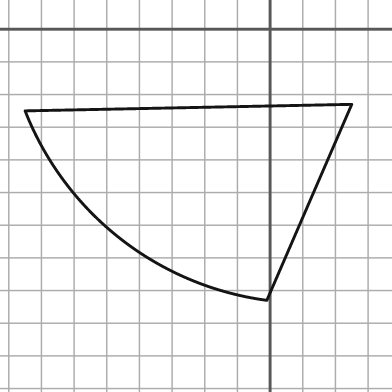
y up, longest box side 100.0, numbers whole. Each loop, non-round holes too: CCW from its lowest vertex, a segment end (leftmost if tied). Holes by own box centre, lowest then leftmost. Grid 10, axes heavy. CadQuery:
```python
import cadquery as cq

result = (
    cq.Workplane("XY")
    .moveTo(-1.0, -83.0)
    .lineTo(25.0, -23.0)
    .lineTo(-75.0, -25.0)
    .threePointArc((-46.0, -64.0), (-1.0, -83.0))
    .close()
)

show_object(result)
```